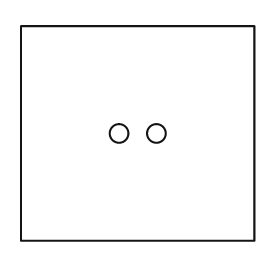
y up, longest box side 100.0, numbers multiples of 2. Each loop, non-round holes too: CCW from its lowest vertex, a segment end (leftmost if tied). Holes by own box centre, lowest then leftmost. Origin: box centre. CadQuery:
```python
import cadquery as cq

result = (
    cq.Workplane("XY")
    .moveTo(-50.0, -46.0)
    .lineTo(50.0, -46.0)
    .lineTo(50.0, 46.0)
    .lineTo(-50.0, 46.0)
    .close()
    .moveTo(-8.0, 0.0)
    .circle(4.0)
    .moveTo(8.0, 0.0)
    .circle(4.0)
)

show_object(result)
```